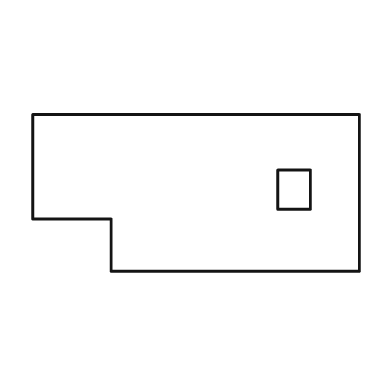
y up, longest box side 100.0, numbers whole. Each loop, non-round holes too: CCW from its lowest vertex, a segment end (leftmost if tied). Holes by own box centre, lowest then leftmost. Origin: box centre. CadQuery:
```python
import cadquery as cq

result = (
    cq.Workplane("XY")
    .moveTo(-26.0, -24.0)
    .lineTo(50.0, -24.0)
    .lineTo(50.0, 24.0)
    .lineTo(-50.0, 24.0)
    .lineTo(-50.0, -8.0)
    .lineTo(-26.0, -8.0)
    .close()
    .moveTo(25.0, -5.0)
    .lineTo(35.0, -5.0)
    .lineTo(35.0, 7.0)
    .lineTo(25.0, 7.0)
    .close()
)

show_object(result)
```